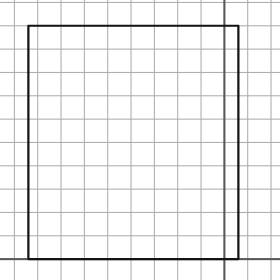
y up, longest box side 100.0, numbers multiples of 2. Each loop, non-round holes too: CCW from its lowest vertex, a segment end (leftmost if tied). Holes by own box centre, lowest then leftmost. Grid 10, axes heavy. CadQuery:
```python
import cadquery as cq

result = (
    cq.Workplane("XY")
    .moveTo(-84.0, 0.0)
    .lineTo(6.0, 0.0)
    .lineTo(6.0, 100.0)
    .lineTo(-84.0, 100.0)
    .close()
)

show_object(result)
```